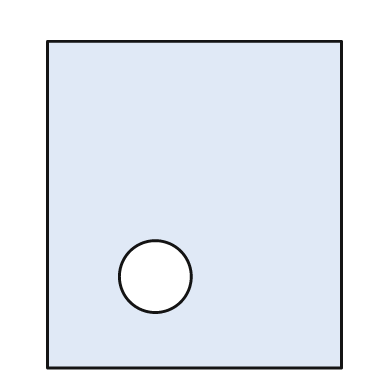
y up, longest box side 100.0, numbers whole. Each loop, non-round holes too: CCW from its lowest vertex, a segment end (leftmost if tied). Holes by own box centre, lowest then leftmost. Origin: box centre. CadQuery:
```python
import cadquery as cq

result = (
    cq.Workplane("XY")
    .moveTo(-45.0, -50.0)
    .lineTo(45.0, -50.0)
    .lineTo(45.0, 50.0)
    .lineTo(-45.0, 50.0)
    .close()
    .moveTo(-12.0, -22.0)
    .circle(11.0)
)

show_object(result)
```